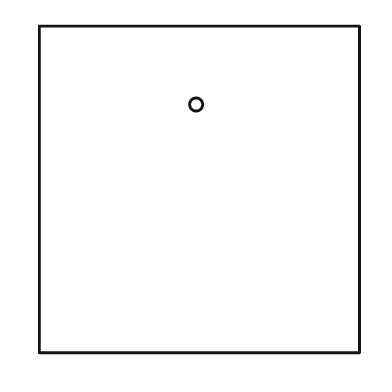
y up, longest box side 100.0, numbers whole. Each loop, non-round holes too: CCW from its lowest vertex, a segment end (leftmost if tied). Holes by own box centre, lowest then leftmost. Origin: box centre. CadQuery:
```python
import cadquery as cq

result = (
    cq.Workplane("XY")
    .moveTo(-49.0, -50.0)
    .lineTo(49.0, -50.0)
    .lineTo(49.0, 50.0)
    .lineTo(-49.0, 50.0)
    .close()
    .moveTo(-1.0, 26.0)
    .circle(2.0)
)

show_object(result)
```